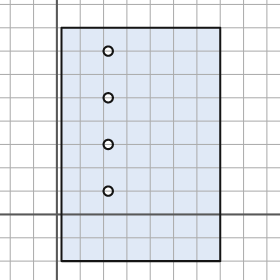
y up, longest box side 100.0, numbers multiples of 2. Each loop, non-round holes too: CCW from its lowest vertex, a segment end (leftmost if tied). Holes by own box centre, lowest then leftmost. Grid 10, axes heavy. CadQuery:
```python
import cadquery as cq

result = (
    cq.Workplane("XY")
    .moveTo(2.0, -20.0)
    .lineTo(70.0, -20.0)
    .lineTo(70.0, 80.0)
    .lineTo(2.0, 80.0)
    .close()
    .moveTo(22.0, 10.0)
    .circle(2.0)
    .moveTo(22.0, 30.0)
    .circle(2.0)
    .moveTo(22.0, 50.0)
    .circle(2.0)
    .moveTo(22.0, 70.0)
    .circle(2.0)
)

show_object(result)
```